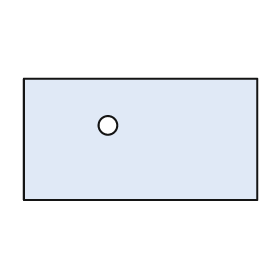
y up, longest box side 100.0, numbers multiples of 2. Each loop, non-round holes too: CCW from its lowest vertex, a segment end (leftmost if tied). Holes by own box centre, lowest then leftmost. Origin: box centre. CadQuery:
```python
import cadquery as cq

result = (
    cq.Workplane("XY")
    .moveTo(-50.0, -26.0)
    .lineTo(50.0, -26.0)
    .lineTo(50.0, 26.0)
    .lineTo(-50.0, 26.0)
    .close()
    .moveTo(-14.0, 6.0)
    .circle(4.0)
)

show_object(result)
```